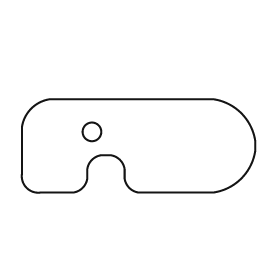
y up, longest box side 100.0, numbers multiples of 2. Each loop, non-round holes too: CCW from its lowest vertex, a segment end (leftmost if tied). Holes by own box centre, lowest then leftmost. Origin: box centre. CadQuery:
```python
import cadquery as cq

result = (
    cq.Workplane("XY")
    .moveTo(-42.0, -20.0)
    .lineTo(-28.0, -20.0)
    .threePointArc((-24.0, -18.0), (-22.0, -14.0))
    .lineTo(-22.0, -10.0)
    .threePointArc((-20.0, -6.0), (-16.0, -4.0))
    .lineTo(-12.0, -4.0)
    .threePointArc((-8.0, -6.0), (-6.0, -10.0))
    .lineTo(-6.0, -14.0)
    .threePointArc((-4.0, -18.0), (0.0, -20.0))
    .lineTo(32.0, -20.0)
    .threePointArc((44.0, -14.0), (50.0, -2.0))
    .lineTo(50.0, 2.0)
    .threePointArc((44.0, 14.0), (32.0, 20.0))
    .lineTo(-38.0, 20.0)
    .threePointArc((-46.0, 16.0), (-50.0, 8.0))
    .lineTo(-50.0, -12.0)
    .threePointArc((-48.0, -18.0), (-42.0, -20.0))
    .close()
    .moveTo(-20.0, 6.0)
    .circle(4.0)
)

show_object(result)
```